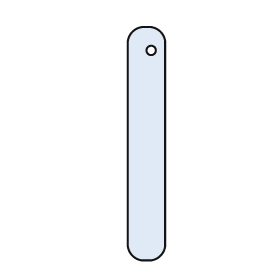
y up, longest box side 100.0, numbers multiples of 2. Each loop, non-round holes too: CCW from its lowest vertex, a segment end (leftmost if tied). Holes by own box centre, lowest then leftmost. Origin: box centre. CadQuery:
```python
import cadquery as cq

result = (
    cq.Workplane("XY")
    .moveTo(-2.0, -50.0)
    .lineTo(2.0, -50.0)
    .threePointArc((6.0, -48.0), (8.0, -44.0))
    .lineTo(8.0, 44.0)
    .threePointArc((6.0, 48.0), (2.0, 50.0))
    .lineTo(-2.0, 50.0)
    .threePointArc((-6.0, 48.0), (-8.0, 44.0))
    .lineTo(-8.0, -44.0)
    .threePointArc((-6.0, -48.0), (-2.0, -50.0))
    .close()
    .moveTo(2.0, 40.0)
    .circle(2.0)
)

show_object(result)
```